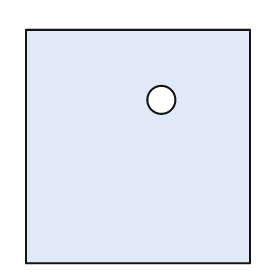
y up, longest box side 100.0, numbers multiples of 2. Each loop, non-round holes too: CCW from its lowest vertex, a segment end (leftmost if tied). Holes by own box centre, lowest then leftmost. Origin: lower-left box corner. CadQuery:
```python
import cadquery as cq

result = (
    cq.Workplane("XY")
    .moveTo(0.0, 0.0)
    .lineTo(96.0, 0.0)
    .lineTo(96.0, 100.0)
    .lineTo(0.0, 100.0)
    .close()
    .moveTo(58.0, 70.0)
    .circle(6.0)
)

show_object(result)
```